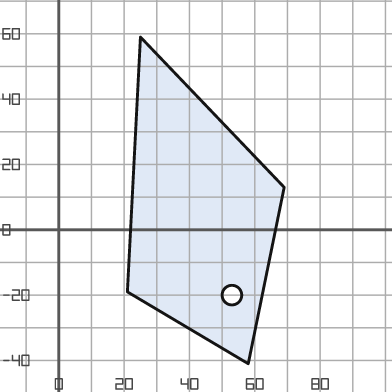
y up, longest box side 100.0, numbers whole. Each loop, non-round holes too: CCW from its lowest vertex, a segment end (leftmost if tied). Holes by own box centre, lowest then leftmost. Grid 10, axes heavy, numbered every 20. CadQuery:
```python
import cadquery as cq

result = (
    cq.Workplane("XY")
    .moveTo(58.0, -41.0)
    .lineTo(69.0, 13.0)
    .lineTo(25.0, 59.0)
    .lineTo(21.0, -19.0)
    .close()
    .moveTo(53.0, -20.0)
    .circle(3.0)
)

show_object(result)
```